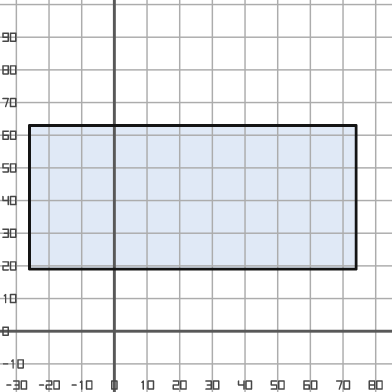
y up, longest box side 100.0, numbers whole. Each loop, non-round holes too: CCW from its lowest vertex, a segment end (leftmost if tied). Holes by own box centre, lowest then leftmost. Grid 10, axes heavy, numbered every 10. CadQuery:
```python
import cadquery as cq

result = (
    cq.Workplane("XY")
    .moveTo(-26.0, 19.0)
    .lineTo(74.0, 19.0)
    .lineTo(74.0, 63.0)
    .lineTo(-26.0, 63.0)
    .close()
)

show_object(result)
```